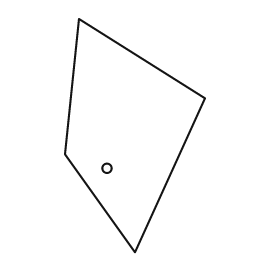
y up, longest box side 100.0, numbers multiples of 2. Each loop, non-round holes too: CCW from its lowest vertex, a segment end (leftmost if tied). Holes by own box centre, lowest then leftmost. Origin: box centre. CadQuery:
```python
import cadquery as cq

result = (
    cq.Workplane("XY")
    .moveTo(0.0, -50.0)
    .lineTo(30.0, 16.0)
    .lineTo(-24.0, 50.0)
    .lineTo(-30.0, -8.0)
    .close()
    .moveTo(-12.0, -14.0)
    .circle(2.0)
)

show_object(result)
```